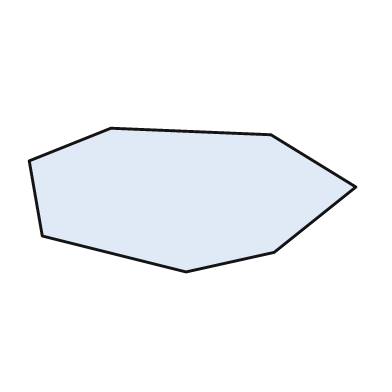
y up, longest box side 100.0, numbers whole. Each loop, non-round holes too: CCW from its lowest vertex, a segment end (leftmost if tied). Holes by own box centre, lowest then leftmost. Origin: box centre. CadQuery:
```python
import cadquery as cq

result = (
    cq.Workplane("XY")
    .moveTo(-2.0, -22.0)
    .lineTo(25.0, -16.0)
    .lineTo(50.0, 4.0)
    .lineTo(24.0, 20.0)
    .lineTo(-25.0, 22.0)
    .lineTo(-50.0, 12.0)
    .lineTo(-46.0, -11.0)
    .close()
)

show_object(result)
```